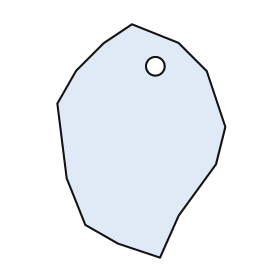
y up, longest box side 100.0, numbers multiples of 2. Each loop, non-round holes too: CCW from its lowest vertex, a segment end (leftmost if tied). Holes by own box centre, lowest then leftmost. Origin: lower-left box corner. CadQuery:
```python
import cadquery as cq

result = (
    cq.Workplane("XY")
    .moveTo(44.0, 0.0)
    .lineTo(52.0, 18.0)
    .lineTo(68.0, 40.0)
    .lineTo(72.0, 56.0)
    .lineTo(64.0, 80.0)
    .lineTo(52.0, 92.0)
    .lineTo(32.0, 100.0)
    .lineTo(20.0, 92.0)
    .lineTo(8.0, 80.0)
    .lineTo(0.0, 66.0)
    .lineTo(4.0, 34.0)
    .lineTo(12.0, 14.0)
    .lineTo(26.0, 6.0)
    .close()
    .moveTo(42.0, 82.0)
    .circle(4.0)
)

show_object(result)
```